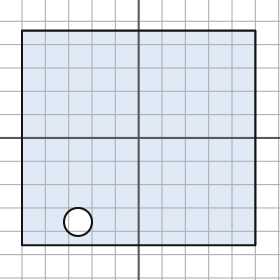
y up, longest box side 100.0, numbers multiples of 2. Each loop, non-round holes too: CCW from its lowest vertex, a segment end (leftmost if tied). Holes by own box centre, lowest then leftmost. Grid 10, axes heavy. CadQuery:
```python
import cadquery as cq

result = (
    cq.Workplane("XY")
    .moveTo(-50.0, -46.0)
    .lineTo(50.0, -46.0)
    .lineTo(50.0, 46.0)
    .lineTo(-50.0, 46.0)
    .close()
    .moveTo(-26.0, -36.0)
    .circle(6.0)
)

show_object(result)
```